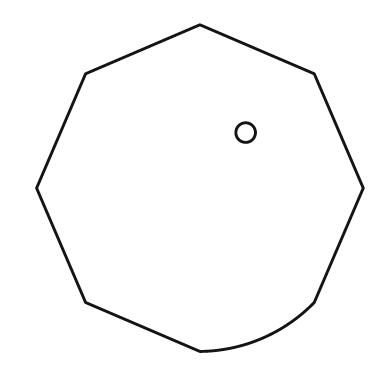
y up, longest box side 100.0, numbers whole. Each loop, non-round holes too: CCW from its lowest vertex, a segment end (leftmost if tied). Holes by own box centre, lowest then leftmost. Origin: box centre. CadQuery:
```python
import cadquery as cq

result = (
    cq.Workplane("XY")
    .moveTo(0.0, -50.0)
    .threePointArc((19.0, -46.0), (35.0, -35.0))
    .lineTo(50.0, 0.0)
    .lineTo(35.0, 35.0)
    .lineTo(0.0, 50.0)
    .lineTo(-35.0, 35.0)
    .lineTo(-50.0, 0.0)
    .lineTo(-35.0, -35.0)
    .close()
    .moveTo(14.0, 17.0)
    .circle(3.0)
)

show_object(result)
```